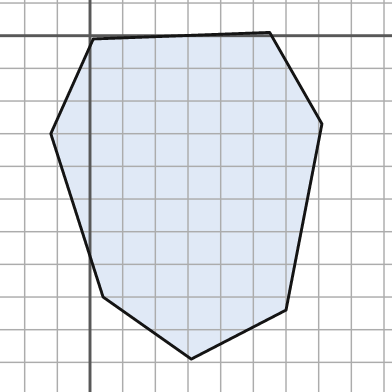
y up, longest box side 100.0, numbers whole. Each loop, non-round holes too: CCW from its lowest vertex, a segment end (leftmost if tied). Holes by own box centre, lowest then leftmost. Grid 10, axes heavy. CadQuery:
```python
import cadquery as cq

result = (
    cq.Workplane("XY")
    .moveTo(31.0, -99.0)
    .lineTo(60.0, -84.0)
    .lineTo(71.0, -27.0)
    .lineTo(55.0, 1.0)
    .lineTo(1.0, -1.0)
    .lineTo(-12.0, -30.0)
    .lineTo(4.0, -80.0)
    .close()
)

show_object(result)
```